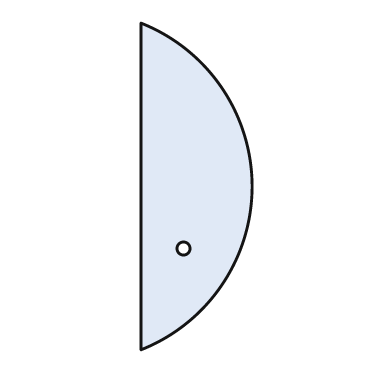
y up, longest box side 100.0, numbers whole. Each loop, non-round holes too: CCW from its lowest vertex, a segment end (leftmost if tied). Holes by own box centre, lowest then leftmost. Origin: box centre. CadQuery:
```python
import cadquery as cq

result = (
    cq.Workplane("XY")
    .moveTo(-17.0, -50.0)
    .threePointArc((17.0, 0.0), (-17.0, 50.0))
    .close()
    .moveTo(-4.0, -19.0)
    .circle(2.0)
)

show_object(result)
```